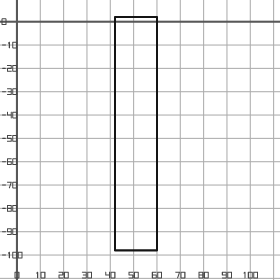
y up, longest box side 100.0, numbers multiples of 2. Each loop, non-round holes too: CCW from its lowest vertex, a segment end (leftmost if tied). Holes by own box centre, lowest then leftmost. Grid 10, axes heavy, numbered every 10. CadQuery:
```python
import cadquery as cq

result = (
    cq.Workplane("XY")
    .moveTo(42.0, -98.0)
    .lineTo(60.0, -98.0)
    .lineTo(60.0, 2.0)
    .lineTo(42.0, 2.0)
    .close()
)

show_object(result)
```